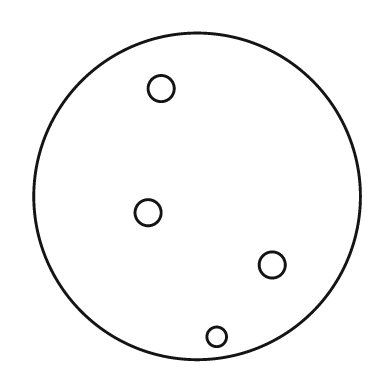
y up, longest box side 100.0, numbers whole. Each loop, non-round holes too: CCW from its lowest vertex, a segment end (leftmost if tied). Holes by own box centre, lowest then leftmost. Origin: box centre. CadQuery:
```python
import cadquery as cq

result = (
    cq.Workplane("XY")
    .moveTo(0.0, 0.0)
    .circle(50.0)
    .moveTo(6.0, -43.0)
    .circle(3.0)
    .moveTo(23.0, -21.0)
    .circle(4.0)
    .moveTo(-15.0, -5.0)
    .circle(4.0)
    .moveTo(-11.0, 33.0)
    .circle(4.0)
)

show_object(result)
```